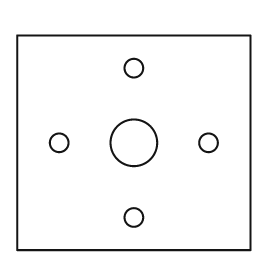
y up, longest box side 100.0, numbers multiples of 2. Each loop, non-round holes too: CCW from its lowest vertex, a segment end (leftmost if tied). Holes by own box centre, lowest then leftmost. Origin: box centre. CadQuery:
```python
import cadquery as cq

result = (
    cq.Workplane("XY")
    .moveTo(-50.0, -46.0)
    .lineTo(50.0, -46.0)
    .lineTo(50.0, 46.0)
    .lineTo(-50.0, 46.0)
    .close()
    .moveTo(0.0, -32.0)
    .circle(4.0)
    .moveTo(-32.0, 0.0)
    .circle(4.0)
    .moveTo(0.0, 0.0)
    .circle(10.0)
    .moveTo(32.0, 0.0)
    .circle(4.0)
    .moveTo(0.0, 32.0)
    .circle(4.0)
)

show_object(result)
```